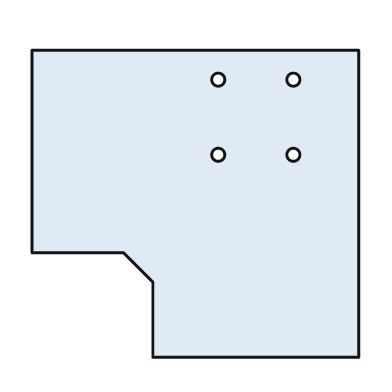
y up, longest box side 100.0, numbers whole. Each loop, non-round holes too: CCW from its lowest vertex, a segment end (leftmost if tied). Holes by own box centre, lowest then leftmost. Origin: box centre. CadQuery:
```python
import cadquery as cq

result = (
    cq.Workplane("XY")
    .moveTo(-13.0, -47.0)
    .lineTo(50.0, -47.0)
    .lineTo(50.0, 47.0)
    .lineTo(-50.0, 47.0)
    .lineTo(-50.0, -15.0)
    .lineTo(-22.0, -15.0)
    .lineTo(-13.0, -24.0)
    .close()
    .moveTo(7.0, 15.0)
    .circle(2.0)
    .moveTo(30.0, 15.0)
    .circle(2.0)
    .moveTo(7.0, 38.0)
    .circle(2.0)
    .moveTo(30.0, 38.0)
    .circle(2.0)
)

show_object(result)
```